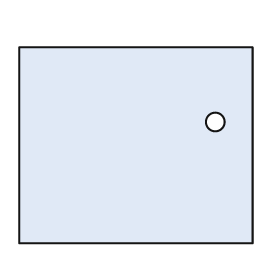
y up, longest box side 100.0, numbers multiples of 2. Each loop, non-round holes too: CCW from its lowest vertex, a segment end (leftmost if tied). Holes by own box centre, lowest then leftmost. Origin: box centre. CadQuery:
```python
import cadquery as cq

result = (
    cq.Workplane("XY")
    .moveTo(-50.0, -42.0)
    .lineTo(50.0, -42.0)
    .lineTo(50.0, 42.0)
    .lineTo(-50.0, 42.0)
    .close()
    .moveTo(34.0, 10.0)
    .circle(4.0)
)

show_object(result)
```